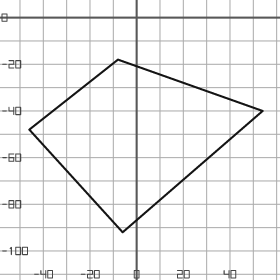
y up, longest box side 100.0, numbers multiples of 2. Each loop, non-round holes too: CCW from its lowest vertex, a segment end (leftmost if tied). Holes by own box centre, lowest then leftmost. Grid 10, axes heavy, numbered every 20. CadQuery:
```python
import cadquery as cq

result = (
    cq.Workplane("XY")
    .moveTo(-6.0, -92.0)
    .lineTo(54.0, -40.0)
    .lineTo(-8.0, -18.0)
    .lineTo(-46.0, -48.0)
    .close()
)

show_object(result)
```